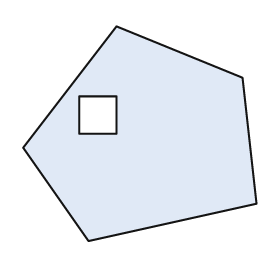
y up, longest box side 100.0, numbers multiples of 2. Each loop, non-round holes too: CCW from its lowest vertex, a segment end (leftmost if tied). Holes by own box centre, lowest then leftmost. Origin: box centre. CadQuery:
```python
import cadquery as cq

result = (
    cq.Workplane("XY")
    .moveTo(-22.0, -46.0)
    .lineTo(50.0, -30.0)
    .lineTo(44.0, 24.0)
    .lineTo(-10.0, 46.0)
    .lineTo(-50.0, -6.0)
    .close()
    .moveTo(-26.0, 0.0)
    .lineTo(-10.0, 0.0)
    .lineTo(-10.0, 16.0)
    .lineTo(-26.0, 16.0)
    .close()
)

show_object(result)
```